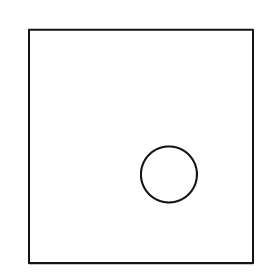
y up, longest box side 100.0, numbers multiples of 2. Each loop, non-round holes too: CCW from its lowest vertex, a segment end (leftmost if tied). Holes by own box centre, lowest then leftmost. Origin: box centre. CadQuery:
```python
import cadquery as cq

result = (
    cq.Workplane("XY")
    .moveTo(-48.0, -50.0)
    .lineTo(48.0, -50.0)
    .lineTo(48.0, 50.0)
    .lineTo(-48.0, 50.0)
    .close()
    .moveTo(12.0, -12.0)
    .circle(12.0)
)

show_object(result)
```